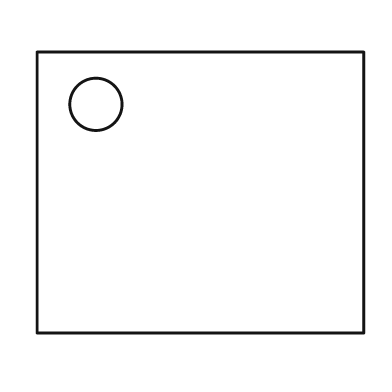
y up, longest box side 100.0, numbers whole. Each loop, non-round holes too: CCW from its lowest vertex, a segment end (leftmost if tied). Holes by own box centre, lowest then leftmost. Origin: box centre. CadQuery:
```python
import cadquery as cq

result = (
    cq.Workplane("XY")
    .moveTo(-50.0, -43.0)
    .lineTo(50.0, -43.0)
    .lineTo(50.0, 43.0)
    .lineTo(-50.0, 43.0)
    .close()
    .moveTo(-32.0, 27.0)
    .circle(8.0)
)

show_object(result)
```